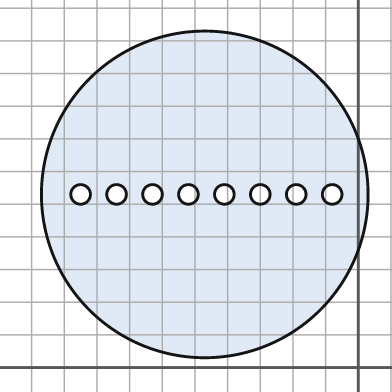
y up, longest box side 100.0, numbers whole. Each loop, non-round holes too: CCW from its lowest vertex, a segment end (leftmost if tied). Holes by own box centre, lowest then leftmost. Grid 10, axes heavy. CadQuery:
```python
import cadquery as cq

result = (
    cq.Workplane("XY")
    .moveTo(-47.0, 53.0)
    .circle(50.0)
    .moveTo(-85.0, 53.0)
    .circle(3.0)
    .moveTo(-74.0, 53.0)
    .circle(3.0)
    .moveTo(-63.0, 53.0)
    .circle(3.0)
    .moveTo(-52.0, 53.0)
    .circle(3.0)
    .moveTo(-41.0, 53.0)
    .circle(3.0)
    .moveTo(-30.0, 53.0)
    .circle(3.0)
    .moveTo(-19.0, 53.0)
    .circle(3.0)
    .moveTo(-8.0, 53.0)
    .circle(3.0)
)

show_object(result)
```